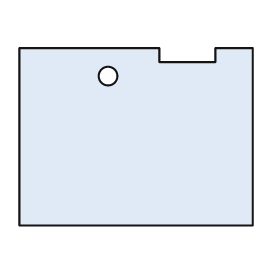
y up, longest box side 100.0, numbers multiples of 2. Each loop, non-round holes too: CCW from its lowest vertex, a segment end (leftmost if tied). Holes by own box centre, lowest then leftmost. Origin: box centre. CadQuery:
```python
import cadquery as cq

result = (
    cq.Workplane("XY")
    .moveTo(-50.0, -38.0)
    .lineTo(50.0, -38.0)
    .lineTo(50.0, 38.0)
    .lineTo(34.0, 38.0)
    .lineTo(34.0, 32.0)
    .lineTo(10.0, 32.0)
    .lineTo(10.0, 38.0)
    .lineTo(-50.0, 38.0)
    .close()
    .moveTo(-12.0, 26.0)
    .circle(4.0)
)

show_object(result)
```